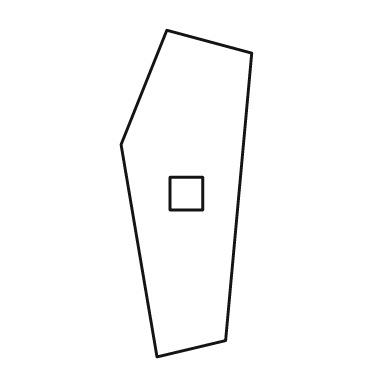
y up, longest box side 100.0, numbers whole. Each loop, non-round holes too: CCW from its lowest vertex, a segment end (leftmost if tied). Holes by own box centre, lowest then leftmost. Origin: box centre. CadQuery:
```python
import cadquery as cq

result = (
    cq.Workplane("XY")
    .moveTo(-9.0, -50.0)
    .lineTo(12.0, -45.0)
    .lineTo(20.0, 43.0)
    .lineTo(-6.0, 50.0)
    .lineTo(-20.0, 15.0)
    .close()
    .moveTo(-5.0, -5.0)
    .lineTo(5.0, -5.0)
    .lineTo(5.0, 5.0)
    .lineTo(-5.0, 5.0)
    .close()
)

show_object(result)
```